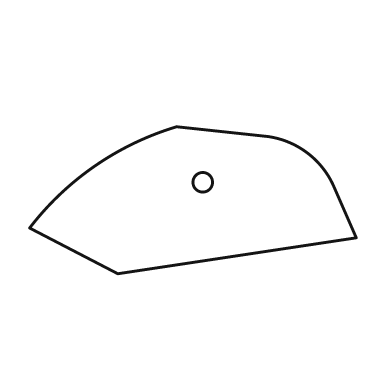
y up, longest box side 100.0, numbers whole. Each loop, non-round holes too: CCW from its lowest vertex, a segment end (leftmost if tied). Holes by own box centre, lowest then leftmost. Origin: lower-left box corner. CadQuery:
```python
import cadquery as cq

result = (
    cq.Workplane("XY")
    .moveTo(27.0, 0.0)
    .lineTo(100.0, 11.0)
    .lineTo(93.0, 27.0)
    .threePointArc((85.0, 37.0), (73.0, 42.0))
    .lineTo(45.0, 45.0)
    .threePointArc((20.0, 33.0), (0.0, 14.0))
    .close()
    .moveTo(53.0, 28.0)
    .circle(3.0)
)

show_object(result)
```